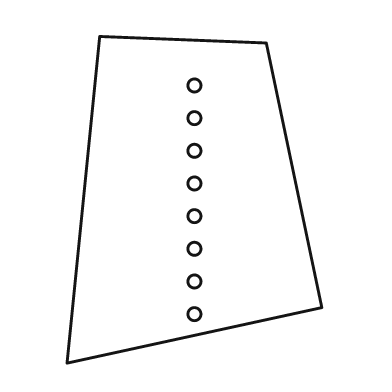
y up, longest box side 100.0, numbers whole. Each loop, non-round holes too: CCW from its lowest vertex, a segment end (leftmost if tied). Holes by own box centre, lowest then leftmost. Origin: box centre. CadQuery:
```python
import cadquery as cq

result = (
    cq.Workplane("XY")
    .moveTo(-39.0, -50.0)
    .lineTo(39.0, -33.0)
    .lineTo(22.0, 48.0)
    .lineTo(-29.0, 50.0)
    .close()
    .moveTo(0.0, -35.0)
    .circle(2.0)
    .moveTo(0.0, -25.0)
    .circle(2.0)
    .moveTo(0.0, -15.0)
    .circle(2.0)
    .moveTo(0.0, -5.0)
    .circle(2.0)
    .moveTo(0.0, 5.0)
    .circle(2.0)
    .moveTo(0.0, 15.0)
    .circle(2.0)
    .moveTo(0.0, 25.0)
    .circle(2.0)
    .moveTo(0.0, 35.0)
    .circle(2.0)
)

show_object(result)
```